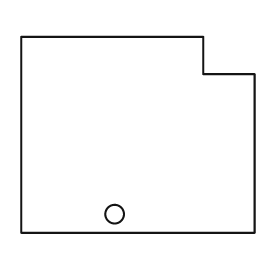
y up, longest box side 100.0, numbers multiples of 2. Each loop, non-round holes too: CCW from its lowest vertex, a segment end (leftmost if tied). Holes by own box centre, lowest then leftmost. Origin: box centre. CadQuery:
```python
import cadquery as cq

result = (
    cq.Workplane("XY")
    .moveTo(-50.0, -42.0)
    .lineTo(50.0, -42.0)
    .lineTo(50.0, 26.0)
    .lineTo(28.0, 26.0)
    .lineTo(28.0, 42.0)
    .lineTo(-50.0, 42.0)
    .close()
    .moveTo(-10.0, -34.0)
    .circle(4.0)
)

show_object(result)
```